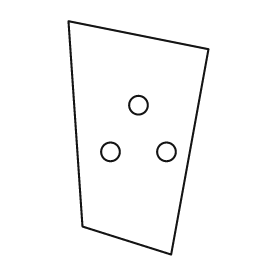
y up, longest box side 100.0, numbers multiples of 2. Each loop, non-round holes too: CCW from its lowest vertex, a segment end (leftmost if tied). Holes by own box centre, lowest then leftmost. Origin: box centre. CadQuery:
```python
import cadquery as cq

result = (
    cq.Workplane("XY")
    .moveTo(14.0, -50.0)
    .lineTo(30.0, 38.0)
    .lineTo(-30.0, 50.0)
    .lineTo(-24.0, -38.0)
    .close()
    .moveTo(-12.0, -6.0)
    .circle(4.0)
    .moveTo(12.0, -6.0)
    .circle(4.0)
    .moveTo(0.0, 14.0)
    .circle(4.0)
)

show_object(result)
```